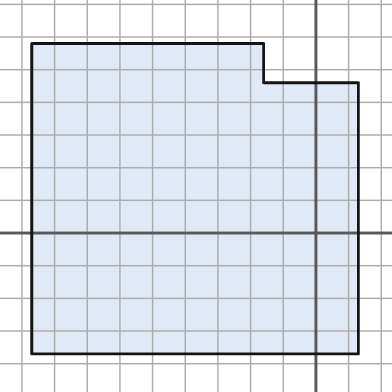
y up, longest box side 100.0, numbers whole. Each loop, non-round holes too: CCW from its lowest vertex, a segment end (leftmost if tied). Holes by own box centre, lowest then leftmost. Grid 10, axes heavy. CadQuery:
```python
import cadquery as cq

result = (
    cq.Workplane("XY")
    .moveTo(-87.0, -37.0)
    .lineTo(13.0, -37.0)
    .lineTo(13.0, 46.0)
    .lineTo(-16.0, 46.0)
    .lineTo(-16.0, 58.0)
    .lineTo(-87.0, 58.0)
    .close()
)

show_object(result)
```